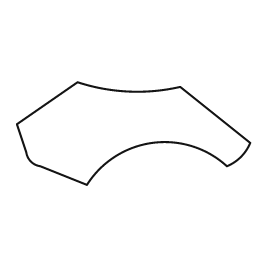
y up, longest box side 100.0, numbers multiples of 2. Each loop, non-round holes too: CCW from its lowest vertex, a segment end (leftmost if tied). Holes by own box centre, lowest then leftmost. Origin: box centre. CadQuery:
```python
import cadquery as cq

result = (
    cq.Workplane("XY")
    .moveTo(-20.0, -22.0)
    .threePointArc((8.0, -4.0), (40.0, -14.0))
    .threePointArc((46.0, -10.0), (50.0, -4.0))
    .lineTo(20.0, 20.0)
    .threePointArc((-2.0, 18.0), (-24.0, 22.0))
    .lineTo(-50.0, 4.0)
    .lineTo(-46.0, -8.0)
    .threePointArc((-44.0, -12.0), (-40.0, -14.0))
    .close()
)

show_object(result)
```